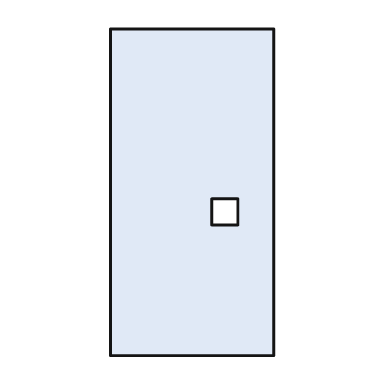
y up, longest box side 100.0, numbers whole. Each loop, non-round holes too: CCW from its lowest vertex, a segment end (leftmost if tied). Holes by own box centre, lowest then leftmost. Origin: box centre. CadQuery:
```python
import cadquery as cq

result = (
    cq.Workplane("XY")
    .moveTo(-25.0, -50.0)
    .lineTo(25.0, -50.0)
    .lineTo(25.0, 50.0)
    .lineTo(-25.0, 50.0)
    .close()
    .moveTo(6.0, -10.0)
    .lineTo(14.0, -10.0)
    .lineTo(14.0, -2.0)
    .lineTo(6.0, -2.0)
    .close()
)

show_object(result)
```